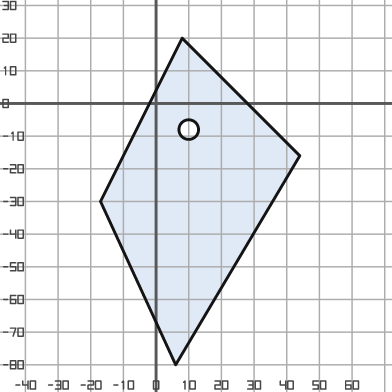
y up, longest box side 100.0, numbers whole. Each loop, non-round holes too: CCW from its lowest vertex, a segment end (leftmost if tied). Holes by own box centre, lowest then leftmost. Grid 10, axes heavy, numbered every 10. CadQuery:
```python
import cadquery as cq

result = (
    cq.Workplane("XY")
    .moveTo(6.0, -80.0)
    .lineTo(44.0, -16.0)
    .lineTo(8.0, 20.0)
    .lineTo(-17.0, -30.0)
    .close()
    .moveTo(10.0, -8.0)
    .circle(3.0)
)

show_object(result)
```